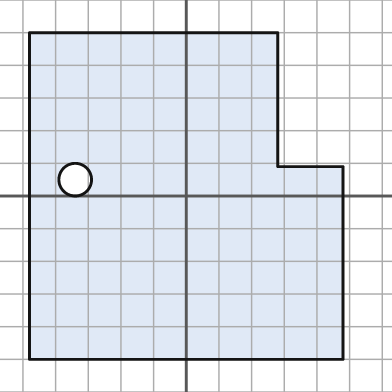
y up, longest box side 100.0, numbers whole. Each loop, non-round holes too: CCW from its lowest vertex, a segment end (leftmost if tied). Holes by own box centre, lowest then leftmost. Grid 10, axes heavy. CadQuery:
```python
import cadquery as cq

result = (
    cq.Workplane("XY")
    .moveTo(-48.0, -50.0)
    .lineTo(48.0, -50.0)
    .lineTo(48.0, 9.0)
    .lineTo(28.0, 9.0)
    .lineTo(28.0, 50.0)
    .lineTo(-48.0, 50.0)
    .close()
    .moveTo(-34.0, 5.0)
    .circle(5.0)
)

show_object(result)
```